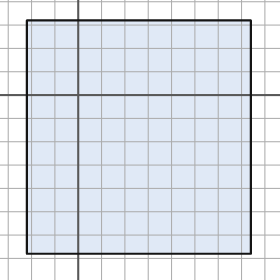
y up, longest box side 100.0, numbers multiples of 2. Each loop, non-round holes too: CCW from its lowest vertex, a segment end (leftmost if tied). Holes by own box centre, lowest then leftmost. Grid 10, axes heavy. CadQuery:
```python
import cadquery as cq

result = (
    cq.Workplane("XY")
    .moveTo(-22.0, -68.0)
    .lineTo(74.0, -68.0)
    .lineTo(74.0, 32.0)
    .lineTo(-22.0, 32.0)
    .close()
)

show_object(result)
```